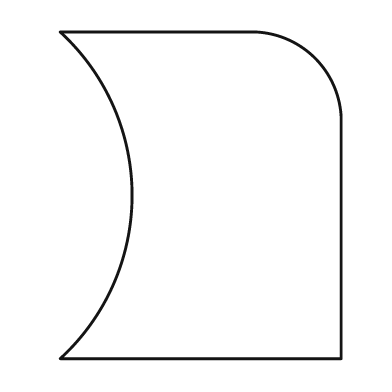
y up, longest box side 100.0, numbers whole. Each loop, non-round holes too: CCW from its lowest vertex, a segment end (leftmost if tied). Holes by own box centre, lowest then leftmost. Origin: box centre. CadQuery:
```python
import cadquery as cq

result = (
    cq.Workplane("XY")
    .moveTo(-43.0, -50.0)
    .lineTo(43.0, -50.0)
    .lineTo(43.0, 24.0)
    .threePointArc((35.0, 42.0), (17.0, 50.0))
    .lineTo(-43.0, 50.0)
    .threePointArc((-21.0, 0.0), (-43.0, -50.0))
    .close()
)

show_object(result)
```